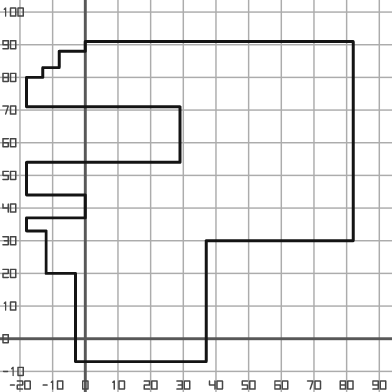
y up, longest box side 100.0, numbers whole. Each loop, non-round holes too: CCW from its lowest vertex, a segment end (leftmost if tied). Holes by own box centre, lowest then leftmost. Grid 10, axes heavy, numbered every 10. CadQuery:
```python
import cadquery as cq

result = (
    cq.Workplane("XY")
    .moveTo(-3.0, -7.0)
    .lineTo(37.0, -7.0)
    .lineTo(37.0, 30.0)
    .lineTo(82.0, 30.0)
    .lineTo(82.0, 91.0)
    .lineTo(0.0, 91.0)
    .lineTo(0.0, 88.0)
    .lineTo(-8.0, 88.0)
    .lineTo(-8.0, 83.0)
    .lineTo(-13.0, 83.0)
    .lineTo(-13.0, 80.0)
    .lineTo(-18.0, 80.0)
    .lineTo(-18.0, 71.0)
    .lineTo(29.0, 71.0)
    .lineTo(29.0, 54.0)
    .lineTo(-18.0, 54.0)
    .lineTo(-18.0, 44.0)
    .lineTo(0.0, 44.0)
    .lineTo(0.0, 37.0)
    .lineTo(-18.0, 37.0)
    .lineTo(-18.0, 33.0)
    .lineTo(-12.0, 33.0)
    .lineTo(-12.0, 20.0)
    .lineTo(-3.0, 20.0)
    .close()
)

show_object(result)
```